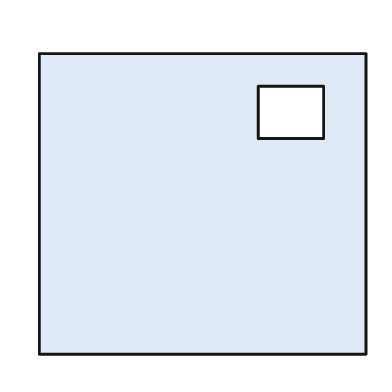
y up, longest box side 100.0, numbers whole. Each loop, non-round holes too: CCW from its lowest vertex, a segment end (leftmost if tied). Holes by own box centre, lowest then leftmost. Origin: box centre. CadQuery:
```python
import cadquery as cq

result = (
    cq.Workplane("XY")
    .moveTo(-50.0, -46.0)
    .lineTo(50.0, -46.0)
    .lineTo(50.0, 46.0)
    .lineTo(-50.0, 46.0)
    .close()
    .moveTo(17.0, 20.0)
    .lineTo(37.0, 20.0)
    .lineTo(37.0, 36.0)
    .lineTo(17.0, 36.0)
    .close()
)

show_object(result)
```